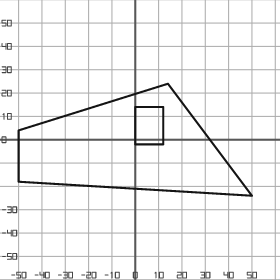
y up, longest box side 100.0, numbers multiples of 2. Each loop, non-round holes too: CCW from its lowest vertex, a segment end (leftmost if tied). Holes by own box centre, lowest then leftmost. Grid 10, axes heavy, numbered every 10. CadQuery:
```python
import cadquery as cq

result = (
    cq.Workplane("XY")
    .moveTo(50.0, -24.0)
    .lineTo(14.0, 24.0)
    .lineTo(-50.0, 4.0)
    .lineTo(-50.0, -18.0)
    .close()
    .moveTo(0.0, -2.0)
    .lineTo(12.0, -2.0)
    .lineTo(12.0, 14.0)
    .lineTo(0.0, 14.0)
    .close()
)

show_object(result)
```